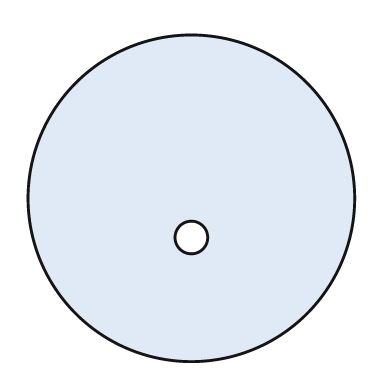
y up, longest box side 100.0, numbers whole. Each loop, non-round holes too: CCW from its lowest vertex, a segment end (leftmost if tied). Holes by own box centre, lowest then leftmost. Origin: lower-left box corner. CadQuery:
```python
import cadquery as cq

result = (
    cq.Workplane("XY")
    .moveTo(50.0, 50.0)
    .circle(50.0)
    .moveTo(50.0, 38.0)
    .circle(5.0)
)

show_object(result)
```